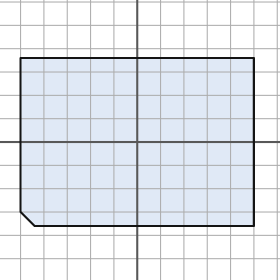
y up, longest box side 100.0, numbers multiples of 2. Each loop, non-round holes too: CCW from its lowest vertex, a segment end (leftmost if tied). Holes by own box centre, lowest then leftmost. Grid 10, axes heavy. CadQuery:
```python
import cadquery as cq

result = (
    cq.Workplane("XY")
    .moveTo(-44.0, -36.0)
    .lineTo(50.0, -36.0)
    .lineTo(50.0, 36.0)
    .lineTo(-50.0, 36.0)
    .lineTo(-50.0, -30.0)
    .close()
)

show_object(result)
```